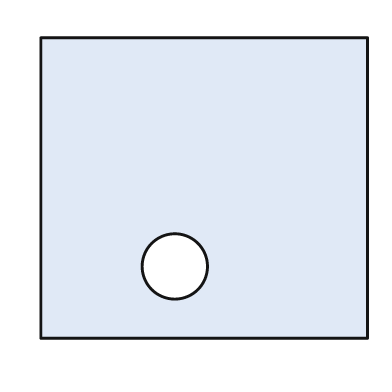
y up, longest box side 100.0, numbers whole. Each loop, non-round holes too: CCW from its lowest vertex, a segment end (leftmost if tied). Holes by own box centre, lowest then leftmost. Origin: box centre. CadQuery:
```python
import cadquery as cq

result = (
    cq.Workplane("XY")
    .moveTo(-50.0, -46.0)
    .lineTo(50.0, -46.0)
    .lineTo(50.0, 46.0)
    .lineTo(-50.0, 46.0)
    .close()
    .moveTo(-9.0, -24.0)
    .circle(10.0)
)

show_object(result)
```